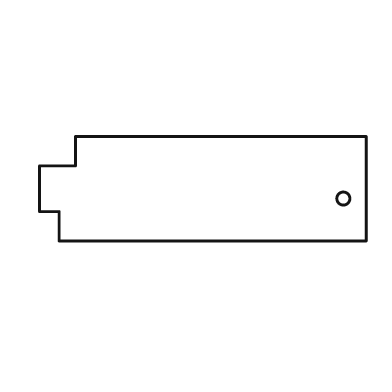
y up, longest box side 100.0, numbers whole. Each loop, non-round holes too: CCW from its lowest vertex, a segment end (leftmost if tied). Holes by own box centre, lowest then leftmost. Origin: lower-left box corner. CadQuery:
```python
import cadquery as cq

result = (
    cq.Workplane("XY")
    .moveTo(6.0, 0.0)
    .lineTo(100.0, 0.0)
    .lineTo(100.0, 32.0)
    .lineTo(11.0, 32.0)
    .lineTo(11.0, 23.0)
    .lineTo(0.0, 23.0)
    .lineTo(0.0, 9.0)
    .lineTo(6.0, 9.0)
    .close()
    .moveTo(93.0, 13.0)
    .circle(2.0)
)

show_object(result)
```